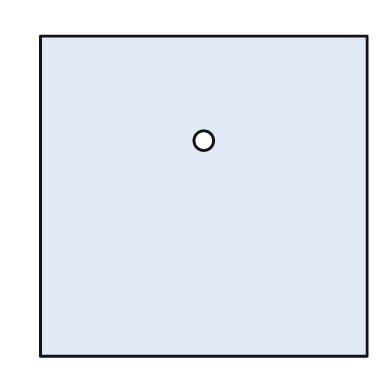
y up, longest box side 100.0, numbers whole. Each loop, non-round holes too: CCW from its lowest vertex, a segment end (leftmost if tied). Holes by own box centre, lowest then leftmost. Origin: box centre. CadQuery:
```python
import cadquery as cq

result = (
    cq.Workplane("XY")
    .moveTo(-50.0, -49.0)
    .lineTo(50.0, -49.0)
    .lineTo(50.0, 49.0)
    .lineTo(-50.0, 49.0)
    .close()
    .moveTo(0.0, 17.0)
    .circle(3.0)
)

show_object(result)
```